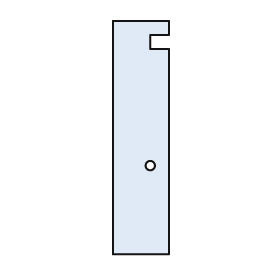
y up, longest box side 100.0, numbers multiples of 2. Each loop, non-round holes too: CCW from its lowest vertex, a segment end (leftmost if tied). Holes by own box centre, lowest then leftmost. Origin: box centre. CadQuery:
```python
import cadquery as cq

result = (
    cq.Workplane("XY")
    .moveTo(-12.0, -50.0)
    .lineTo(12.0, -50.0)
    .lineTo(12.0, 38.0)
    .lineTo(4.0, 38.0)
    .lineTo(4.0, 44.0)
    .lineTo(12.0, 44.0)
    .lineTo(12.0, 50.0)
    .lineTo(-12.0, 50.0)
    .close()
    .moveTo(4.0, -12.0)
    .circle(2.0)
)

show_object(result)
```